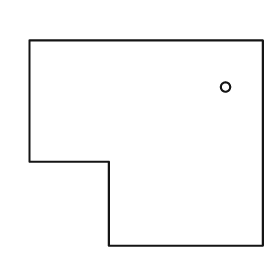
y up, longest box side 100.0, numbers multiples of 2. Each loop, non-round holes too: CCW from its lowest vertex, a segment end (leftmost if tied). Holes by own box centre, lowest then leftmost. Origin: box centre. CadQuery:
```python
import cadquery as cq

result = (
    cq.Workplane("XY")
    .moveTo(-16.0, -44.0)
    .lineTo(50.0, -44.0)
    .lineTo(50.0, 44.0)
    .lineTo(-50.0, 44.0)
    .lineTo(-50.0, -8.0)
    .lineTo(-16.0, -8.0)
    .close()
    .moveTo(34.0, 24.0)
    .circle(2.0)
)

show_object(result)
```